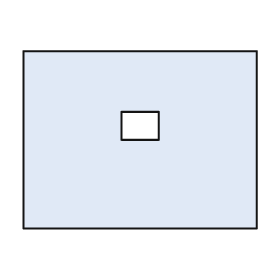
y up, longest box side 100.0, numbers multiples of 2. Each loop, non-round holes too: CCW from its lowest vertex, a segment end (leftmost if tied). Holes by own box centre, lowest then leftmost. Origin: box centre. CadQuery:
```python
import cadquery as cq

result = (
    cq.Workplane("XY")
    .moveTo(-50.0, -38.0)
    .lineTo(50.0, -38.0)
    .lineTo(50.0, 38.0)
    .lineTo(-50.0, 38.0)
    .close()
    .moveTo(-8.0, 0.0)
    .lineTo(8.0, 0.0)
    .lineTo(8.0, 12.0)
    .lineTo(-8.0, 12.0)
    .close()
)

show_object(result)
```